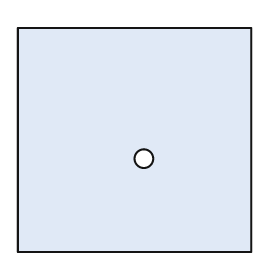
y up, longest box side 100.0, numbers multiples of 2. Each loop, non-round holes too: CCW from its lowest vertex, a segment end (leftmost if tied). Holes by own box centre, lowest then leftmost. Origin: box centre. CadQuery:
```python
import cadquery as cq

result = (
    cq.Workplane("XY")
    .moveTo(-50.0, -48.0)
    .lineTo(50.0, -48.0)
    .lineTo(50.0, 48.0)
    .lineTo(-50.0, 48.0)
    .close()
    .moveTo(4.0, -8.0)
    .circle(4.0)
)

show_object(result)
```